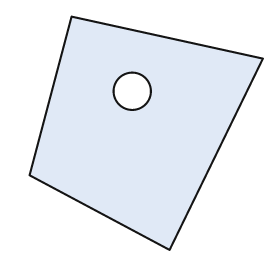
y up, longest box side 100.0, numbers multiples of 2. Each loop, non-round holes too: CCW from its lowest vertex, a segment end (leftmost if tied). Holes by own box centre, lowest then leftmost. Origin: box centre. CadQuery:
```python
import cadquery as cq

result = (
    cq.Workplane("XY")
    .moveTo(10.0, -50.0)
    .lineTo(50.0, 32.0)
    .lineTo(-32.0, 50.0)
    .lineTo(-50.0, -18.0)
    .close()
    .moveTo(-6.0, 18.0)
    .circle(8.0)
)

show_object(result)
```